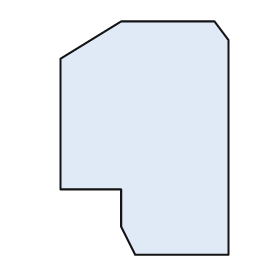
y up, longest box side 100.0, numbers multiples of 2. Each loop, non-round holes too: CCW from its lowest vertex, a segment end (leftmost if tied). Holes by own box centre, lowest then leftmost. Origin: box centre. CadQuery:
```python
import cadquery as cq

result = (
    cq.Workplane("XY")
    .moveTo(-4.0, -50.0)
    .lineTo(36.0, -50.0)
    .lineTo(36.0, 42.0)
    .lineTo(30.0, 50.0)
    .lineTo(-10.0, 50.0)
    .lineTo(-36.0, 34.0)
    .lineTo(-36.0, -22.0)
    .lineTo(-10.0, -22.0)
    .lineTo(-10.0, -38.0)
    .close()
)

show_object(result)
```